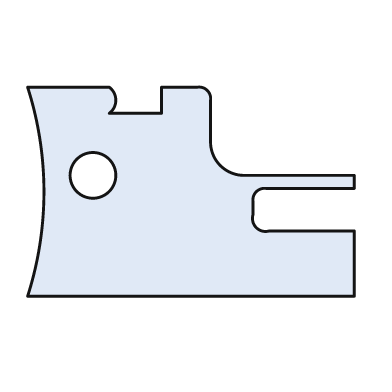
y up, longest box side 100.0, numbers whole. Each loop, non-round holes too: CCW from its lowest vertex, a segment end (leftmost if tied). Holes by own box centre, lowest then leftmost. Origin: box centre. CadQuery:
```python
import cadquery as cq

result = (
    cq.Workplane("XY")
    .moveTo(-50.0, -32.0)
    .lineTo(50.0, -32.0)
    .lineTo(50.0, -12.0)
    .lineTo(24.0, -12.0)
    .threePointArc((20.0, -11.0), (19.0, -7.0))
    .lineTo(19.0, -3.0)
    .threePointArc((20.0, 0.0), (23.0, 1.0))
    .lineTo(50.0, 1.0)
    .lineTo(50.0, 5.0)
    .lineTo(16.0, 5.0)
    .threePointArc((9.0, 8.0), (6.0, 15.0))
    .lineTo(6.0, 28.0)
    .threePointArc((5.0, 31.0), (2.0, 32.0))
    .lineTo(-9.0, 32.0)
    .lineTo(-9.0, 24.0)
    .lineTo(-25.0, 24.0)
    .threePointArc((-23.0, 28.0), (-25.0, 32.0))
    .lineTo(-50.0, 32.0)
    .threePointArc((-45.0, 0.0), (-50.0, -32.0))
    .close()
    .moveTo(-30.0, 5.0)
    .circle(7.0)
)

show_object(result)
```